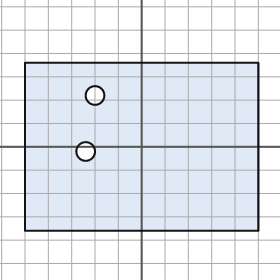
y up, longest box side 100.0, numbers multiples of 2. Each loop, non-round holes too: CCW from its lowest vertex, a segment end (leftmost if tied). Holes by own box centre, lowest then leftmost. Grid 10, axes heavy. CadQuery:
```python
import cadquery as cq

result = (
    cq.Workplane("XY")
    .moveTo(-50.0, -36.0)
    .lineTo(50.0, -36.0)
    .lineTo(50.0, 36.0)
    .lineTo(-50.0, 36.0)
    .close()
    .moveTo(-24.0, -2.0)
    .circle(4.0)
    .moveTo(-20.0, 22.0)
    .circle(4.0)
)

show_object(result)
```